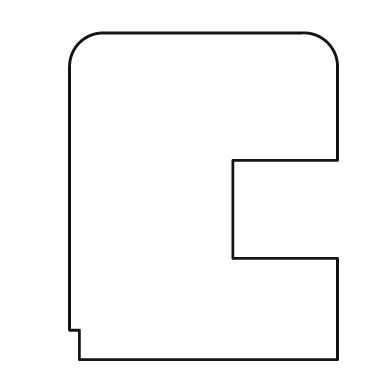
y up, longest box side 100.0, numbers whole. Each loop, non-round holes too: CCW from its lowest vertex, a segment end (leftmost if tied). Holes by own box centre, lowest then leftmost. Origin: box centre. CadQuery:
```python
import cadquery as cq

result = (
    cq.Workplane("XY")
    .moveTo(-38.0, -50.0)
    .lineTo(41.0, -50.0)
    .lineTo(41.0, -19.0)
    .lineTo(9.0, -19.0)
    .lineTo(9.0, 11.0)
    .lineTo(41.0, 11.0)
    .lineTo(41.0, 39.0)
    .threePointArc((38.0, 47.0), (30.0, 50.0))
    .lineTo(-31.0, 50.0)
    .threePointArc((-38.0, 47.0), (-41.0, 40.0))
    .lineTo(-41.0, -41.0)
    .lineTo(-38.0, -41.0)
    .close()
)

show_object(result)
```